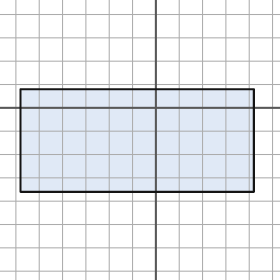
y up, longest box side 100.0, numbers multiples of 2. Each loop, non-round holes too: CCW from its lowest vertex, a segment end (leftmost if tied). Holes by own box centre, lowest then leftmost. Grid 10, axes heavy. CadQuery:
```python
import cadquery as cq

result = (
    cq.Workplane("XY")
    .moveTo(-58.0, -36.0)
    .lineTo(42.0, -36.0)
    .lineTo(42.0, 8.0)
    .lineTo(-58.0, 8.0)
    .close()
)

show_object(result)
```